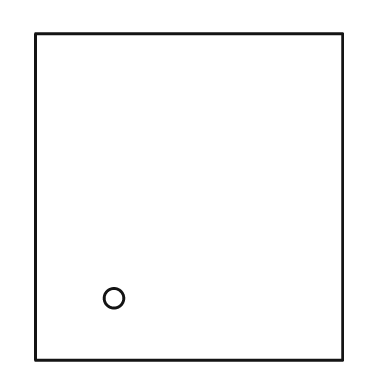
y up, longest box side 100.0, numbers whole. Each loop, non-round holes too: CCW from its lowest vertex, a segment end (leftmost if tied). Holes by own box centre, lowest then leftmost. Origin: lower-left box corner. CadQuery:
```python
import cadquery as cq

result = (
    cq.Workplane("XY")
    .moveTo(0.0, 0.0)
    .lineTo(94.0, 0.0)
    .lineTo(94.0, 100.0)
    .lineTo(0.0, 100.0)
    .close()
    .moveTo(24.0, 19.0)
    .circle(3.0)
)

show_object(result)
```